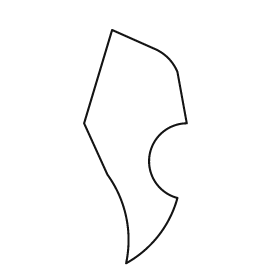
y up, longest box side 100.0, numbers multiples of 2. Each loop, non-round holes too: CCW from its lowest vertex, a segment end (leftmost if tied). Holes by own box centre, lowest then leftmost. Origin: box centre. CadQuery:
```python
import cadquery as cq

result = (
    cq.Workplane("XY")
    .moveTo(-4.0, -50.0)
    .threePointArc((10.0, -38.0), (18.0, -22.0))
    .threePointArc((6.0, -4.0), (22.0, 10.0))
    .lineTo(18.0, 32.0)
    .threePointArc((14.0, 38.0), (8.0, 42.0))
    .lineTo(-10.0, 50.0)
    .lineTo(-22.0, 10.0)
    .lineTo(-12.0, -12.0)
    .threePointArc((-4.0, -30.0), (-4.0, -50.0))
    .close()
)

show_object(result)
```